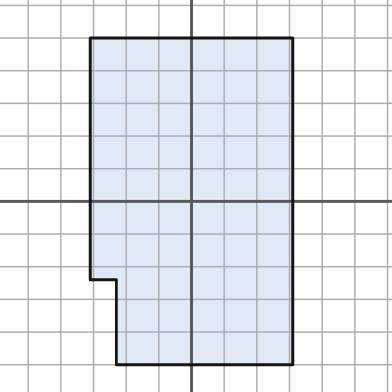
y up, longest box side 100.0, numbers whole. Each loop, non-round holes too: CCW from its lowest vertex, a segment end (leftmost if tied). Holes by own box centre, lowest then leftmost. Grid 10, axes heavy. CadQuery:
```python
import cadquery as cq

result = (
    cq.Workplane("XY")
    .moveTo(-23.0, -50.0)
    .lineTo(31.0, -50.0)
    .lineTo(31.0, 50.0)
    .lineTo(-31.0, 50.0)
    .lineTo(-31.0, -24.0)
    .lineTo(-23.0, -24.0)
    .close()
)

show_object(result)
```